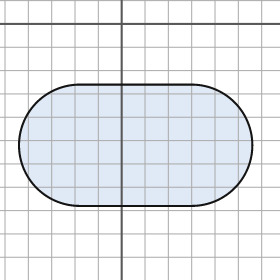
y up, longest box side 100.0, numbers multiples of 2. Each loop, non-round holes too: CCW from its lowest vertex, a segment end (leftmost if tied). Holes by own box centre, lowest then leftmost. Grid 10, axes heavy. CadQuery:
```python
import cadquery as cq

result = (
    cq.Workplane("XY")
    .moveTo(-18.0, -78.0)
    .lineTo(30.0, -78.0)
    .threePointArc((56.0, -52.0), (30.0, -26.0))
    .lineTo(-18.0, -26.0)
    .threePointArc((-44.0, -52.0), (-18.0, -78.0))
    .close()
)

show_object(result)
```